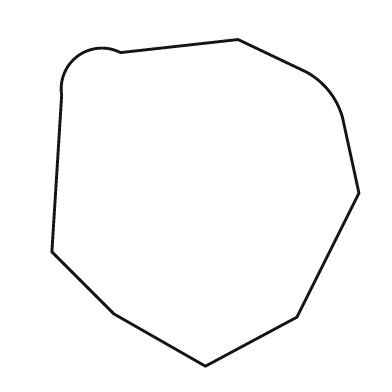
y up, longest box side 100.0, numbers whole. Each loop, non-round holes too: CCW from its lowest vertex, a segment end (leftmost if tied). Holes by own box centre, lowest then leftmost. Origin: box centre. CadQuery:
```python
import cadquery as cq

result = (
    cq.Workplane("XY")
    .moveTo(0.0, -50.0)
    .lineTo(28.0, -35.0)
    .lineTo(47.0, 3.0)
    .lineTo(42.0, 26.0)
    .threePointArc((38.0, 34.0), (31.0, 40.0))
    .lineTo(10.0, 50.0)
    .lineTo(-26.0, 46.0)
    .threePointArc((-39.0, 45.0), (-44.0, 33.0))
    .lineTo(-47.0, -15.0)
    .lineTo(-28.0, -34.0)
    .close()
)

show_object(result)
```